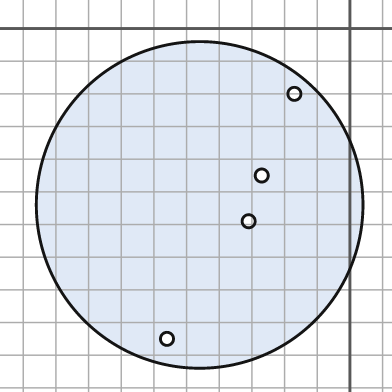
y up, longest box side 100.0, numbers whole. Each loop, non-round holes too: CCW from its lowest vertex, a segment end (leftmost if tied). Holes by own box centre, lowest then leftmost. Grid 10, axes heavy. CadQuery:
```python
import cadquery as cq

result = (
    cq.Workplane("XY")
    .moveTo(-46.0, -54.0)
    .circle(50.0)
    .moveTo(-56.0, -95.0)
    .circle(2.0)
    .moveTo(-31.0, -59.0)
    .circle(2.0)
    .moveTo(-27.0, -45.0)
    .circle(2.0)
    .moveTo(-17.0, -20.0)
    .circle(2.0)
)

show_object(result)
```